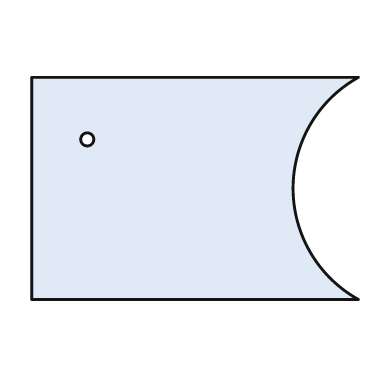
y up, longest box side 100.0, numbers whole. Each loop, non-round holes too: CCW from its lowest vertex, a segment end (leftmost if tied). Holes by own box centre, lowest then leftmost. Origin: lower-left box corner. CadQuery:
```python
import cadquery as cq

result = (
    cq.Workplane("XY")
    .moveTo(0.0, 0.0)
    .lineTo(100.0, 0.0)
    .threePointArc((80.0, 34.0), (100.0, 68.0))
    .lineTo(0.0, 68.0)
    .close()
    .moveTo(17.0, 49.0)
    .circle(2.0)
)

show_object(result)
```